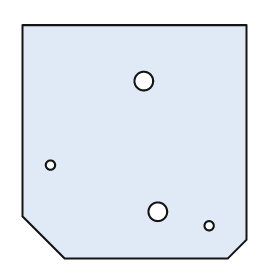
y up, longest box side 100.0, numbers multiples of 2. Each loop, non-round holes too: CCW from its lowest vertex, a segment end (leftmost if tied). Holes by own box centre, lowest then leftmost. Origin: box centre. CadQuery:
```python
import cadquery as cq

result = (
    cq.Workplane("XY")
    .moveTo(-30.0, -50.0)
    .lineTo(40.0, -50.0)
    .lineTo(48.0, -42.0)
    .lineTo(48.0, 50.0)
    .lineTo(-48.0, 50.0)
    .lineTo(-48.0, -32.0)
    .close()
    .moveTo(32.0, -36.0)
    .circle(2.0)
    .moveTo(10.0, -30.0)
    .circle(4.0)
    .moveTo(-36.0, -10.0)
    .circle(2.0)
    .moveTo(4.0, 26.0)
    .circle(4.0)
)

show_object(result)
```